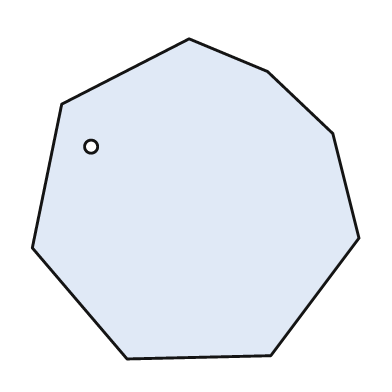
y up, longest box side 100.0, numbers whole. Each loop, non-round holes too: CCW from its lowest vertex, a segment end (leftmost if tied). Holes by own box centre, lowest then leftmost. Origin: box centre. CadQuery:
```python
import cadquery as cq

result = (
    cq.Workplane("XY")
    .moveTo(-21.0, -49.0)
    .lineTo(23.0, -48.0)
    .lineTo(50.0, -12.0)
    .lineTo(42.0, 20.0)
    .lineTo(22.0, 39.0)
    .lineTo(-2.0, 49.0)
    .lineTo(-41.0, 29.0)
    .lineTo(-50.0, -15.0)
    .close()
    .moveTo(-32.0, 16.0)
    .circle(2.0)
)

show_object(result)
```